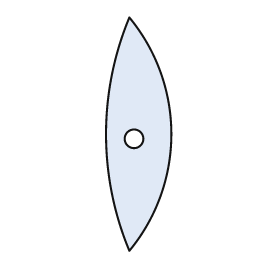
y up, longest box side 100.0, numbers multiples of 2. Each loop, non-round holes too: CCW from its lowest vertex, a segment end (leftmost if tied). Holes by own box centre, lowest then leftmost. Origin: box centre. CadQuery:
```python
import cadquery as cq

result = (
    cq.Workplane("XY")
    .moveTo(-4.0, -50.0)
    .threePointArc((14.0, 0.0), (-4.0, 50.0))
    .threePointArc((-14.0, 0.0), (-4.0, -50.0))
    .close()
    .moveTo(-2.0, -2.0)
    .circle(4.0)
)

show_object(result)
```